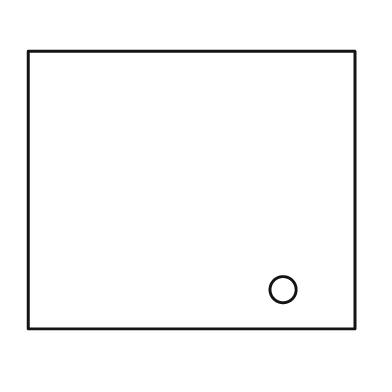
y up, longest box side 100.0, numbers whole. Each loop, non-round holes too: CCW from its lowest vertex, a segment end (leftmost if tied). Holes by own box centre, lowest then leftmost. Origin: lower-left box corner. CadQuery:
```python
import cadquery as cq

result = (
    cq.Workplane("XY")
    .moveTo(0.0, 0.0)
    .lineTo(100.0, 0.0)
    .lineTo(100.0, 85.0)
    .lineTo(0.0, 85.0)
    .close()
    .moveTo(78.0, 12.0)
    .circle(4.0)
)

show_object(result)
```